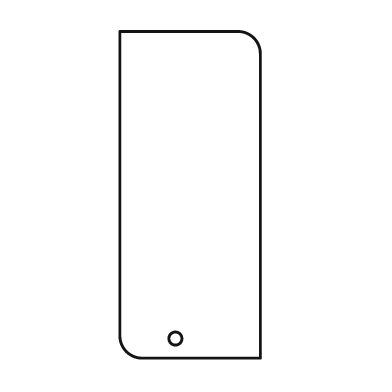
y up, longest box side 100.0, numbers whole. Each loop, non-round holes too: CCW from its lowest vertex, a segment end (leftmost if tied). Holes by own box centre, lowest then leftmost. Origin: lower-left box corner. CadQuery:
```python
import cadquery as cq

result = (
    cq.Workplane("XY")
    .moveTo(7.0, 0.0)
    .lineTo(43.0, 0.0)
    .lineTo(43.0, 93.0)
    .threePointArc((41.0, 98.0), (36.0, 100.0))
    .lineTo(0.0, 100.0)
    .lineTo(0.0, 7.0)
    .threePointArc((2.0, 2.0), (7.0, 0.0))
    .close()
    .moveTo(17.0, 6.0)
    .circle(2.0)
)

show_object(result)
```